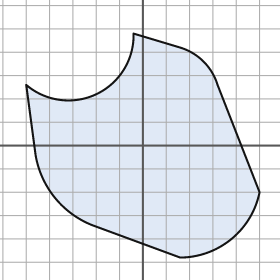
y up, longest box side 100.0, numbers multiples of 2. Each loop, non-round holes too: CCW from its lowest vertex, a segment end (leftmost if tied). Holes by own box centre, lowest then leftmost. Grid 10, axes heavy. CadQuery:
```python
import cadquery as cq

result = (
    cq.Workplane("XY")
    .moveTo(16.0, -48.0)
    .threePointArc((38.0, -40.0), (50.0, -20.0))
    .lineTo(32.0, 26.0)
    .threePointArc((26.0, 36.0), (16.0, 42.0))
    .lineTo(-4.0, 48.0)
    .threePointArc((-20.0, 22.0), (-50.0, 26.0))
    .lineTo(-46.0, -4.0)
    .threePointArc((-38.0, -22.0), (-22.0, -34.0))
    .close()
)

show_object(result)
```